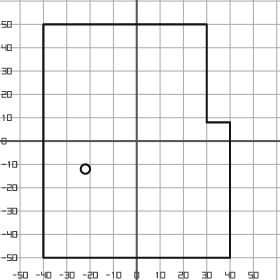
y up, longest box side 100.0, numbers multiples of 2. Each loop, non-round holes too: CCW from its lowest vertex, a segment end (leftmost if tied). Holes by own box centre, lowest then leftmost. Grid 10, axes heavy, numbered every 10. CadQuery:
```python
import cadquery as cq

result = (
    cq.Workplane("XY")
    .moveTo(-40.0, -50.0)
    .lineTo(40.0, -50.0)
    .lineTo(40.0, 8.0)
    .lineTo(30.0, 8.0)
    .lineTo(30.0, 50.0)
    .lineTo(-40.0, 50.0)
    .close()
    .moveTo(-22.0, -12.0)
    .circle(2.0)
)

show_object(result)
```